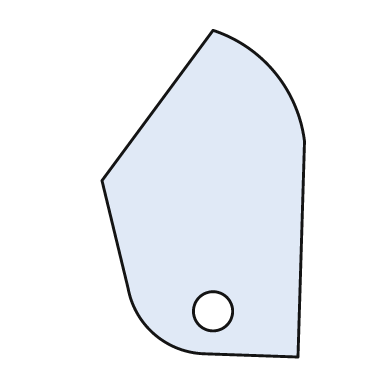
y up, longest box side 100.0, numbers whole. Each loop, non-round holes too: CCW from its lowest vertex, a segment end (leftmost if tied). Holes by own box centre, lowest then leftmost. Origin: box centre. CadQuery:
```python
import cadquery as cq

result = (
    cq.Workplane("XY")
    .moveTo(29.0, -50.0)
    .lineTo(31.0, 16.0)
    .threePointArc((22.0, 37.0), (3.0, 50.0))
    .lineTo(-31.0, 4.0)
    .lineTo(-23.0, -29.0)
    .threePointArc((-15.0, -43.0), (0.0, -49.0))
    .close()
    .moveTo(3.0, -36.0)
    .circle(6.0)
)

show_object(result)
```